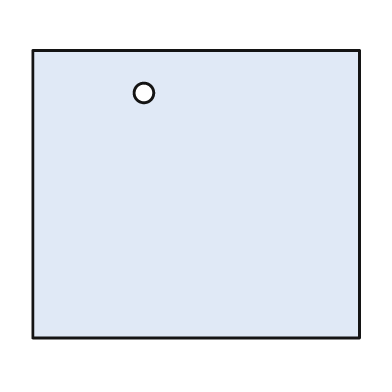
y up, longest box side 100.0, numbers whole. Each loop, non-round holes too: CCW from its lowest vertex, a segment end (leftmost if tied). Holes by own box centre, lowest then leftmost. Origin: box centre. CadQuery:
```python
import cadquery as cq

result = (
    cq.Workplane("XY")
    .moveTo(-50.0, -44.0)
    .lineTo(50.0, -44.0)
    .lineTo(50.0, 44.0)
    .lineTo(-50.0, 44.0)
    .close()
    .moveTo(-16.0, 31.0)
    .circle(3.0)
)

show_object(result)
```